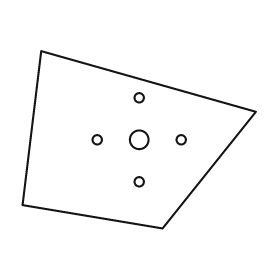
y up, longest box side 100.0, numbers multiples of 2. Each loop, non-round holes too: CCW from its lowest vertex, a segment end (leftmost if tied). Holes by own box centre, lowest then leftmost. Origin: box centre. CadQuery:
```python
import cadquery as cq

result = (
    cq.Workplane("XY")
    .moveTo(10.0, -38.0)
    .lineTo(50.0, 12.0)
    .lineTo(-42.0, 38.0)
    .lineTo(-50.0, -28.0)
    .close()
    .moveTo(0.0, -18.0)
    .circle(2.0)
    .moveTo(-18.0, 0.0)
    .circle(2.0)
    .moveTo(0.0, 0.0)
    .circle(4.0)
    .moveTo(18.0, 0.0)
    .circle(2.0)
    .moveTo(0.0, 18.0)
    .circle(2.0)
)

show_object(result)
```